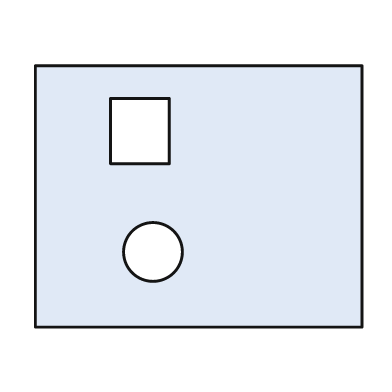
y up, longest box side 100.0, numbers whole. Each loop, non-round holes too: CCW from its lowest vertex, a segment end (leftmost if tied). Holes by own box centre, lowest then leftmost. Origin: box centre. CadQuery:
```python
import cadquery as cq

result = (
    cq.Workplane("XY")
    .moveTo(-50.0, -40.0)
    .lineTo(50.0, -40.0)
    .lineTo(50.0, 40.0)
    .lineTo(-50.0, 40.0)
    .close()
    .moveTo(-14.0, -17.0)
    .circle(9.0)
    .moveTo(-27.0, 10.0)
    .lineTo(-9.0, 10.0)
    .lineTo(-9.0, 30.0)
    .lineTo(-27.0, 30.0)
    .close()
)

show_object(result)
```